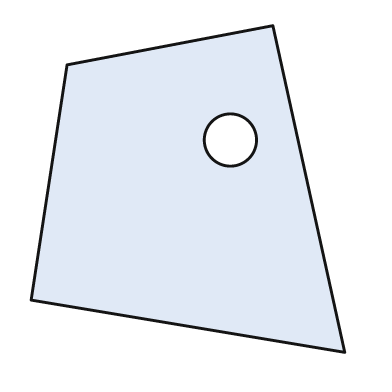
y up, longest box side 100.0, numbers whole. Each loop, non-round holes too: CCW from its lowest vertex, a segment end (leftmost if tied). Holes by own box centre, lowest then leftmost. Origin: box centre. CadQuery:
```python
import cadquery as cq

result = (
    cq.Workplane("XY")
    .moveTo(48.0, -50.0)
    .lineTo(26.0, 50.0)
    .lineTo(-37.0, 38.0)
    .lineTo(-48.0, -34.0)
    .close()
    .moveTo(13.0, 15.0)
    .circle(8.0)
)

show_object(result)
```